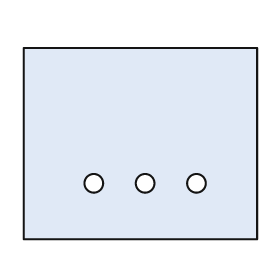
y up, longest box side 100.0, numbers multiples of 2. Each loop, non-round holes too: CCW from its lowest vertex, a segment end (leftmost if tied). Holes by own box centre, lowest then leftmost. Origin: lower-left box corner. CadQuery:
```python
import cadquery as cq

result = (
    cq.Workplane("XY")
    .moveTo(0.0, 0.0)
    .lineTo(100.0, 0.0)
    .lineTo(100.0, 82.0)
    .lineTo(0.0, 82.0)
    .close()
    .moveTo(30.0, 24.0)
    .circle(4.0)
    .moveTo(52.0, 24.0)
    .circle(4.0)
    .moveTo(74.0, 24.0)
    .circle(4.0)
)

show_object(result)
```